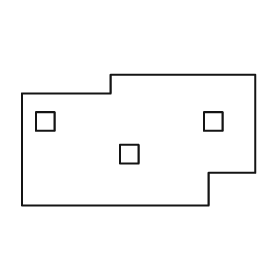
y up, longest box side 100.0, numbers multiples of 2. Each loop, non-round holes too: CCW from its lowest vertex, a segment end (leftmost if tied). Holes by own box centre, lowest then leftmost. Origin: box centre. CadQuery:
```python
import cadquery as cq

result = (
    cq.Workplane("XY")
    .moveTo(-50.0, -28.0)
    .lineTo(30.0, -28.0)
    .lineTo(30.0, -14.0)
    .lineTo(50.0, -14.0)
    .lineTo(50.0, 28.0)
    .lineTo(-12.0, 28.0)
    .lineTo(-12.0, 20.0)
    .lineTo(-50.0, 20.0)
    .close()
    .moveTo(-8.0, -10.0)
    .lineTo(0.0, -10.0)
    .lineTo(0.0, -2.0)
    .lineTo(-8.0, -2.0)
    .close()
    .moveTo(-44.0, 4.0)
    .lineTo(-36.0, 4.0)
    .lineTo(-36.0, 12.0)
    .lineTo(-44.0, 12.0)
    .close()
    .moveTo(28.0, 4.0)
    .lineTo(36.0, 4.0)
    .lineTo(36.0, 12.0)
    .lineTo(28.0, 12.0)
    .close()
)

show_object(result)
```